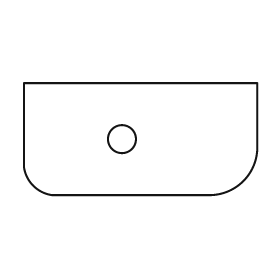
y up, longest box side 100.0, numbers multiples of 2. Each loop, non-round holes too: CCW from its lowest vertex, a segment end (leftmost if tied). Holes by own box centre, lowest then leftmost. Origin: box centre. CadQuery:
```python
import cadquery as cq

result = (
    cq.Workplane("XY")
    .moveTo(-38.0, -24.0)
    .lineTo(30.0, -24.0)
    .threePointArc((44.0, -18.0), (50.0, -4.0))
    .lineTo(50.0, 24.0)
    .lineTo(-50.0, 24.0)
    .lineTo(-50.0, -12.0)
    .threePointArc((-46.0, -20.0), (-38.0, -24.0))
    .close()
    .moveTo(-8.0, 0.0)
    .circle(6.0)
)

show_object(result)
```